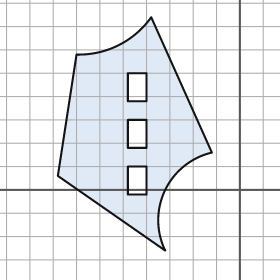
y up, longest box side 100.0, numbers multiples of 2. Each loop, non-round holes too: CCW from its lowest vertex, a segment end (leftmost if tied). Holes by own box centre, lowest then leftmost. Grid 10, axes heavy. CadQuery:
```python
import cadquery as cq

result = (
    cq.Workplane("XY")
    .moveTo(-32.0, -26.0)
    .threePointArc((-32.0, 0.0), (-12.0, 16.0))
    .lineTo(-38.0, 74.0)
    .threePointArc((-52.0, 62.0), (-70.0, 58.0))
    .lineTo(-78.0, 6.0)
    .close()
    .moveTo(-48.0, -2.0)
    .lineTo(-40.0, -2.0)
    .lineTo(-40.0, 10.0)
    .lineTo(-48.0, 10.0)
    .close()
    .moveTo(-48.0, 18.0)
    .lineTo(-40.0, 18.0)
    .lineTo(-40.0, 30.0)
    .lineTo(-48.0, 30.0)
    .close()
    .moveTo(-48.0, 38.0)
    .lineTo(-40.0, 38.0)
    .lineTo(-40.0, 50.0)
    .lineTo(-48.0, 50.0)
    .close()
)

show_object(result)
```